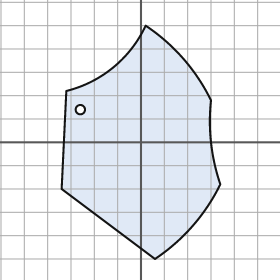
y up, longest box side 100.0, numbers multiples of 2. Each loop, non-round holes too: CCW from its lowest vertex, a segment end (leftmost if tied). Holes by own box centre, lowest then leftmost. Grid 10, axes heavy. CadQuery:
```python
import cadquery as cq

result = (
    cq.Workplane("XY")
    .moveTo(6.0, -50.0)
    .threePointArc((22.0, -36.0), (34.0, -18.0))
    .threePointArc((30.0, 0.0), (30.0, 18.0))
    .threePointArc((18.0, 36.0), (2.0, 50.0))
    .threePointArc((-12.0, 32.0), (-32.0, 22.0))
    .lineTo(-34.0, -20.0)
    .close()
    .moveTo(-26.0, 14.0)
    .circle(2.0)
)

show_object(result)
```